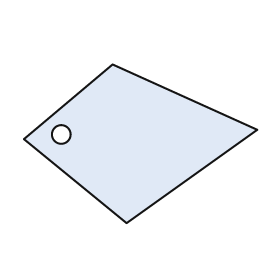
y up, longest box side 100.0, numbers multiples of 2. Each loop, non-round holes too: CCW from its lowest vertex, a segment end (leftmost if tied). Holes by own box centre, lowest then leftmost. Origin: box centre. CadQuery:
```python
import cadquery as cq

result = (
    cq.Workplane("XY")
    .moveTo(-6.0, -34.0)
    .lineTo(50.0, 6.0)
    .lineTo(-12.0, 34.0)
    .lineTo(-50.0, 2.0)
    .close()
    .moveTo(-34.0, 4.0)
    .circle(4.0)
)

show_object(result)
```